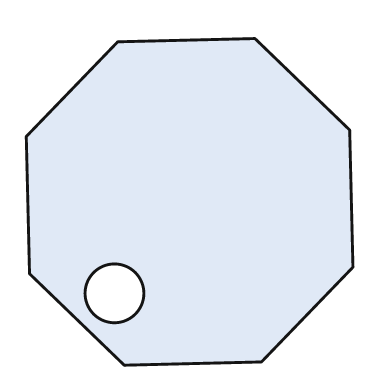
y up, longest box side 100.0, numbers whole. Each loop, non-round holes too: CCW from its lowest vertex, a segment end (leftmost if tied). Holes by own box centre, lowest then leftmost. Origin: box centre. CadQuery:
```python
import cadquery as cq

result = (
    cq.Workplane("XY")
    .moveTo(-20.0, -50.0)
    .lineTo(22.0, -49.0)
    .lineTo(50.0, -20.0)
    .lineTo(49.0, 22.0)
    .lineTo(20.0, 50.0)
    .lineTo(-22.0, 49.0)
    .lineTo(-50.0, 20.0)
    .lineTo(-49.0, -22.0)
    .close()
    .moveTo(-23.0, -28.0)
    .circle(9.0)
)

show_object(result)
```